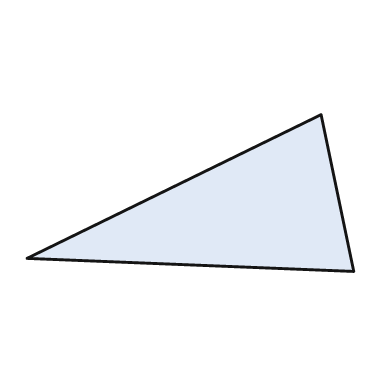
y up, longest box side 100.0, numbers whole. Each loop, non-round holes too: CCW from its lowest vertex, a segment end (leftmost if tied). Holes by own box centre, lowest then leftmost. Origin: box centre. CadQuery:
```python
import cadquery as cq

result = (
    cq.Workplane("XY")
    .moveTo(50.0, -24.0)
    .lineTo(40.0, 24.0)
    .lineTo(-50.0, -20.0)
    .close()
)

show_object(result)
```